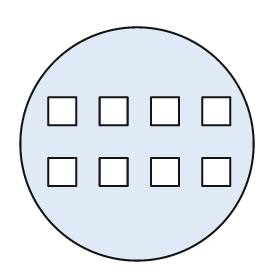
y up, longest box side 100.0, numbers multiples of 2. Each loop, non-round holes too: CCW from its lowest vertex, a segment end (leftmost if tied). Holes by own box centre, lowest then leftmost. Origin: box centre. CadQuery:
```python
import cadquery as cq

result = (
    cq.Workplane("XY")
    .moveTo(0.0, 0.0)
    .circle(50.0)
    .moveTo(-38.0, -18.0)
    .lineTo(-26.0, -18.0)
    .lineTo(-26.0, -6.0)
    .lineTo(-38.0, -6.0)
    .close()
    .moveTo(-16.0, -18.0)
    .lineTo(-4.0, -18.0)
    .lineTo(-4.0, -6.0)
    .lineTo(-16.0, -6.0)
    .close()
    .moveTo(6.0, -18.0)
    .lineTo(18.0, -18.0)
    .lineTo(18.0, -6.0)
    .lineTo(6.0, -6.0)
    .close()
    .moveTo(28.0, -18.0)
    .lineTo(40.0, -18.0)
    .lineTo(40.0, -6.0)
    .lineTo(28.0, -6.0)
    .close()
    .moveTo(-38.0, 8.0)
    .lineTo(-26.0, 8.0)
    .lineTo(-26.0, 20.0)
    .lineTo(-38.0, 20.0)
    .close()
    .moveTo(-16.0, 8.0)
    .lineTo(-4.0, 8.0)
    .lineTo(-4.0, 20.0)
    .lineTo(-16.0, 20.0)
    .close()
    .moveTo(6.0, 8.0)
    .lineTo(18.0, 8.0)
    .lineTo(18.0, 20.0)
    .lineTo(6.0, 20.0)
    .close()
    .moveTo(28.0, 8.0)
    .lineTo(40.0, 8.0)
    .lineTo(40.0, 20.0)
    .lineTo(28.0, 20.0)
    .close()
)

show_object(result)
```